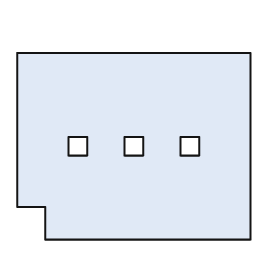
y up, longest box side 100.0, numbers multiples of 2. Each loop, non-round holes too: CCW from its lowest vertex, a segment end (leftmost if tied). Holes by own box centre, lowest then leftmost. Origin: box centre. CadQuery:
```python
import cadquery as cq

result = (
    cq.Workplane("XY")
    .moveTo(-38.0, -40.0)
    .lineTo(50.0, -40.0)
    .lineTo(50.0, 40.0)
    .lineTo(-50.0, 40.0)
    .lineTo(-50.0, -26.0)
    .lineTo(-38.0, -26.0)
    .close()
    .moveTo(-28.0, -4.0)
    .lineTo(-20.0, -4.0)
    .lineTo(-20.0, 4.0)
    .lineTo(-28.0, 4.0)
    .close()
    .moveTo(-4.0, -4.0)
    .lineTo(4.0, -4.0)
    .lineTo(4.0, 4.0)
    .lineTo(-4.0, 4.0)
    .close()
    .moveTo(20.0, -4.0)
    .lineTo(28.0, -4.0)
    .lineTo(28.0, 4.0)
    .lineTo(20.0, 4.0)
    .close()
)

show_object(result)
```